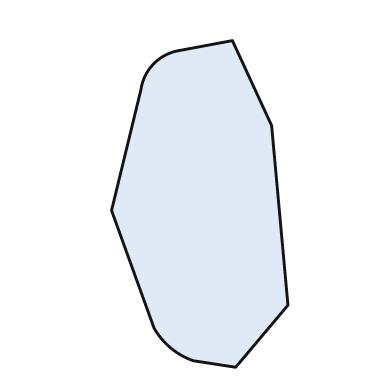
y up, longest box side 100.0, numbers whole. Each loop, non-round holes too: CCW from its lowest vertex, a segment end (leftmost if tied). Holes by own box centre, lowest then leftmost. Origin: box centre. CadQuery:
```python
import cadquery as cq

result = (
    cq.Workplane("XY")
    .moveTo(11.0, -50.0)
    .lineTo(27.0, -31.0)
    .lineTo(22.0, 24.0)
    .lineTo(10.0, 50.0)
    .lineTo(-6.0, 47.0)
    .threePointArc((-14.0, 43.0), (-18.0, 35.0))
    .lineTo(-27.0, -2.0)
    .lineTo(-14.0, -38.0)
    .threePointArc((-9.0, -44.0), (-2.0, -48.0))
    .close()
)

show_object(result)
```